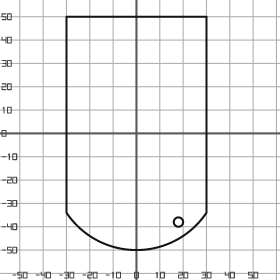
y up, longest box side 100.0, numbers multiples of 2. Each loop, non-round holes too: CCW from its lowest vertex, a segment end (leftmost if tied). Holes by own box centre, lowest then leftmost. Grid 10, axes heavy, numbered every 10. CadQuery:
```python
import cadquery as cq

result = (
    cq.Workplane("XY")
    .moveTo(-30.0, -34.0)
    .threePointArc((0.0, -50.0), (30.0, -34.0))
    .lineTo(30.0, 50.0)
    .lineTo(-30.0, 50.0)
    .close()
    .moveTo(18.0, -38.0)
    .circle(2.0)
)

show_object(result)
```